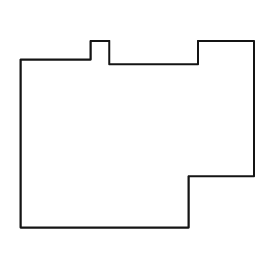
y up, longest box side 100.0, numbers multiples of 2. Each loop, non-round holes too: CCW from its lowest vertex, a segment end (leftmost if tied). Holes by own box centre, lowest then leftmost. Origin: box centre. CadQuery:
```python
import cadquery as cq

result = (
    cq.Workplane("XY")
    .moveTo(-50.0, -40.0)
    .lineTo(22.0, -40.0)
    .lineTo(22.0, -18.0)
    .lineTo(50.0, -18.0)
    .lineTo(50.0, 40.0)
    .lineTo(26.0, 40.0)
    .lineTo(26.0, 30.0)
    .lineTo(-12.0, 30.0)
    .lineTo(-12.0, 40.0)
    .lineTo(-20.0, 40.0)
    .lineTo(-20.0, 32.0)
    .lineTo(-50.0, 32.0)
    .close()
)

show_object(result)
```